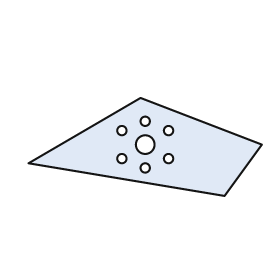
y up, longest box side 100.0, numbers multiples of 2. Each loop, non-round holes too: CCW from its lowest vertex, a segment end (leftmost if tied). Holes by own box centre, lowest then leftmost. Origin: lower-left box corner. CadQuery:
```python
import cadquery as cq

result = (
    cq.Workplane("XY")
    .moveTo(84.0, 0.0)
    .lineTo(100.0, 22.0)
    .lineTo(48.0, 42.0)
    .lineTo(0.0, 14.0)
    .close()
    .moveTo(50.0, 12.0)
    .circle(2.0)
    .moveTo(40.0, 16.0)
    .circle(2.0)
    .moveTo(60.0, 16.0)
    .circle(2.0)
    .moveTo(50.0, 22.0)
    .circle(4.0)
    .moveTo(40.0, 28.0)
    .circle(2.0)
    .moveTo(60.0, 28.0)
    .circle(2.0)
    .moveTo(50.0, 32.0)
    .circle(2.0)
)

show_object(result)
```